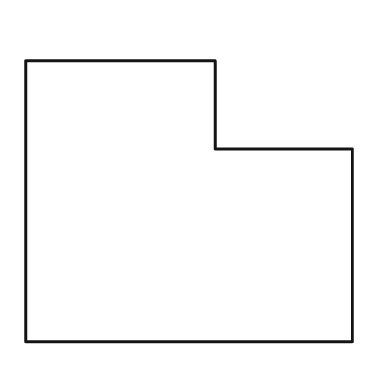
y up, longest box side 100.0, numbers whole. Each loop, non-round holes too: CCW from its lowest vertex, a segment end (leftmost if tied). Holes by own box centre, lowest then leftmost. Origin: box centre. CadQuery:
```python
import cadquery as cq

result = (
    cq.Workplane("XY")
    .moveTo(-50.0, -43.0)
    .lineTo(50.0, -43.0)
    .lineTo(50.0, 16.0)
    .lineTo(8.0, 16.0)
    .lineTo(8.0, 43.0)
    .lineTo(-50.0, 43.0)
    .close()
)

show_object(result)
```